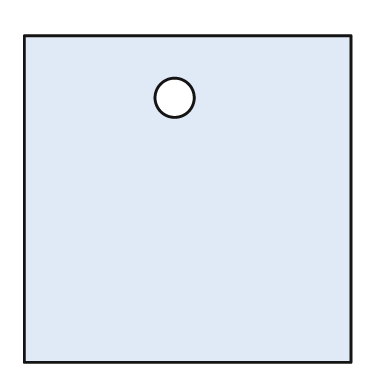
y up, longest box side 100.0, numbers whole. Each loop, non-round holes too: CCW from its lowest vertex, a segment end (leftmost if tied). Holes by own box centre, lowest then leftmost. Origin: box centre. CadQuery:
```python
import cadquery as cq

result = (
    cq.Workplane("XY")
    .moveTo(-50.0, -50.0)
    .lineTo(50.0, -50.0)
    .lineTo(50.0, 50.0)
    .lineTo(-50.0, 50.0)
    .close()
    .moveTo(-4.0, 31.0)
    .circle(6.0)
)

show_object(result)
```